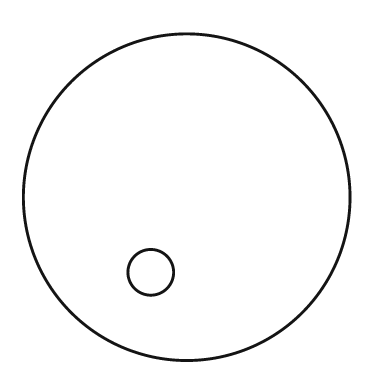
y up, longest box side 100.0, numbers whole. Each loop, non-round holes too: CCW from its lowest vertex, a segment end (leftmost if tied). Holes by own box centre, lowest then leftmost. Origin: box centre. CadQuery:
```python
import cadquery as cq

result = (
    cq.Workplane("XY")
    .moveTo(0.0, 0.0)
    .circle(50.0)
    .moveTo(-11.0, -23.0)
    .circle(7.0)
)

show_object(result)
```